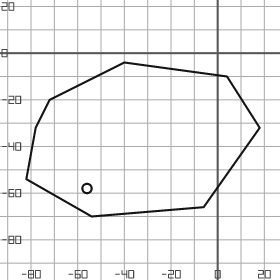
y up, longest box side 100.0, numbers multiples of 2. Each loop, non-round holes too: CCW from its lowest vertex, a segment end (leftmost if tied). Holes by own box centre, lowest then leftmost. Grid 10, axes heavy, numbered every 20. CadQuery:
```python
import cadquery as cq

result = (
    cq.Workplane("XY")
    .moveTo(-54.0, -70.0)
    .lineTo(-6.0, -66.0)
    .lineTo(18.0, -32.0)
    .lineTo(4.0, -10.0)
    .lineTo(-40.0, -4.0)
    .lineTo(-72.0, -20.0)
    .lineTo(-78.0, -32.0)
    .lineTo(-82.0, -54.0)
    .close()
    .moveTo(-56.0, -58.0)
    .circle(2.0)
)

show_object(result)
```